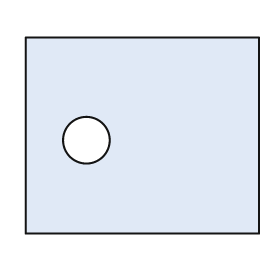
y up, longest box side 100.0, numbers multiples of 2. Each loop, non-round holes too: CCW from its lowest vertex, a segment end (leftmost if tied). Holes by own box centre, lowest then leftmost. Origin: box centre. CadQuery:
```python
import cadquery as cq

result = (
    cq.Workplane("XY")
    .moveTo(-50.0, -42.0)
    .lineTo(50.0, -42.0)
    .lineTo(50.0, 42.0)
    .lineTo(-50.0, 42.0)
    .close()
    .moveTo(-24.0, -2.0)
    .circle(10.0)
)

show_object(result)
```